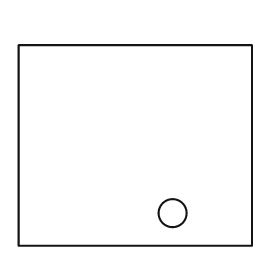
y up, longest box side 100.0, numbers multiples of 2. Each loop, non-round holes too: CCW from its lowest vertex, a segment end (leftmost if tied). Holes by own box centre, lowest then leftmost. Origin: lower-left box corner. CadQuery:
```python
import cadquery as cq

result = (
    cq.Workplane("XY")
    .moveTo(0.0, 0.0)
    .lineTo(100.0, 0.0)
    .lineTo(100.0, 86.0)
    .lineTo(0.0, 86.0)
    .close()
    .moveTo(66.0, 14.0)
    .circle(6.0)
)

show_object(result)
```